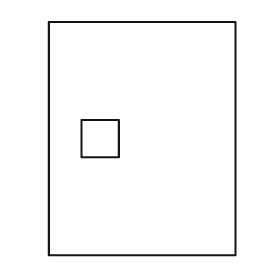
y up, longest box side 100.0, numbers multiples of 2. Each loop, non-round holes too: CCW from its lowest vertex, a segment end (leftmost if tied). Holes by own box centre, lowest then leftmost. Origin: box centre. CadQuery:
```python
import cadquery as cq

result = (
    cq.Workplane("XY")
    .moveTo(-40.0, -50.0)
    .lineTo(40.0, -50.0)
    .lineTo(40.0, 50.0)
    .lineTo(-40.0, 50.0)
    .close()
    .moveTo(-26.0, -8.0)
    .lineTo(-10.0, -8.0)
    .lineTo(-10.0, 8.0)
    .lineTo(-26.0, 8.0)
    .close()
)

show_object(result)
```